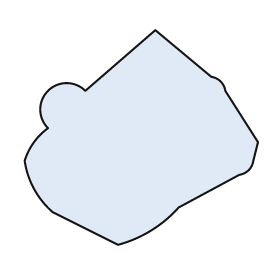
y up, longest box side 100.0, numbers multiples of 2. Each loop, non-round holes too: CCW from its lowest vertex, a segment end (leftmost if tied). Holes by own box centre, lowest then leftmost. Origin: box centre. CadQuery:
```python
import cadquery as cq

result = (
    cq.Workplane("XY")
    .moveTo(-10.0, -46.0)
    .threePointArc((4.0, -40.0), (16.0, -30.0))
    .lineTo(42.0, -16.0)
    .threePointArc((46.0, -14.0), (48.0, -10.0))
    .lineTo(50.0, -2.0)
    .lineTo(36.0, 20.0)
    .threePointArc((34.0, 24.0), (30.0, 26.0))
    .lineTo(6.0, 46.0)
    .lineTo(-24.0, 20.0)
    .threePointArc((-40.0, 20.0), (-40.0, 4.0))
    .threePointArc((-46.0, -2.0), (-50.0, -10.0))
    .threePointArc((-46.0, -22.0), (-38.0, -32.0))
    .close()
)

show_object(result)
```